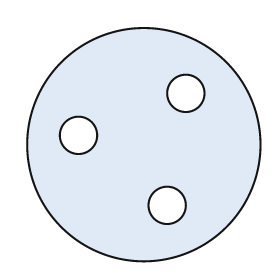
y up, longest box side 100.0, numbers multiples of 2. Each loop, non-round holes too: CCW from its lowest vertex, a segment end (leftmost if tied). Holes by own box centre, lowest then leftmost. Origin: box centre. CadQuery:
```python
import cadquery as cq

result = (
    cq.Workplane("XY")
    .moveTo(0.0, 0.0)
    .circle(50.0)
    .moveTo(10.0, -26.0)
    .circle(8.0)
    .moveTo(-28.0, 4.0)
    .circle(8.0)
    .moveTo(18.0, 22.0)
    .circle(8.0)
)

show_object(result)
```